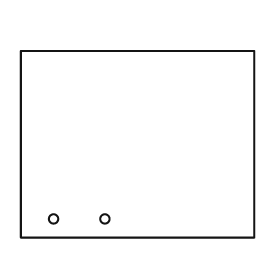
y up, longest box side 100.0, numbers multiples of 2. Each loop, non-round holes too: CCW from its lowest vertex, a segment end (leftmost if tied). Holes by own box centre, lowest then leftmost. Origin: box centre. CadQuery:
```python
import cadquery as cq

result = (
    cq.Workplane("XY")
    .moveTo(-50.0, -40.0)
    .lineTo(50.0, -40.0)
    .lineTo(50.0, 40.0)
    .lineTo(-50.0, 40.0)
    .close()
    .moveTo(-36.0, -32.0)
    .circle(2.0)
    .moveTo(-14.0, -32.0)
    .circle(2.0)
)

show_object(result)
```